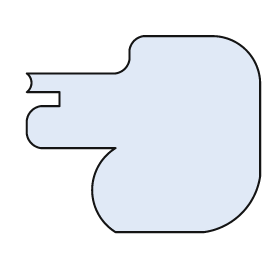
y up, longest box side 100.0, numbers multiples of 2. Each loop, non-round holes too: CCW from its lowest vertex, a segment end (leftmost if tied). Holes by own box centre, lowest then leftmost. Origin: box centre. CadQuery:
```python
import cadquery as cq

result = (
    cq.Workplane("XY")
    .moveTo(-12.0, -42.0)
    .lineTo(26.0, -42.0)
    .threePointArc((42.0, -34.0), (50.0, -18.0))
    .lineTo(50.0, 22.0)
    .threePointArc((44.0, 36.0), (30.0, 42.0))
    .lineTo(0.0, 42.0)
    .threePointArc((-4.0, 40.0), (-6.0, 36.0))
    .lineTo(-6.0, 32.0)
    .threePointArc((-8.0, 28.0), (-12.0, 26.0))
    .lineTo(-50.0, 26.0)
    .threePointArc((-48.0, 22.0), (-50.0, 18.0))
    .lineTo(-36.0, 18.0)
    .lineTo(-36.0, 12.0)
    .lineTo(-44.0, 12.0)
    .threePointArc((-48.0, 10.0), (-50.0, 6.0))
    .lineTo(-50.0, 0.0)
    .threePointArc((-48.0, -4.0), (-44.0, -6.0))
    .lineTo(-12.0, -6.0)
    .threePointArc((-22.0, -24.0), (-12.0, -42.0))
    .close()
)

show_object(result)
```